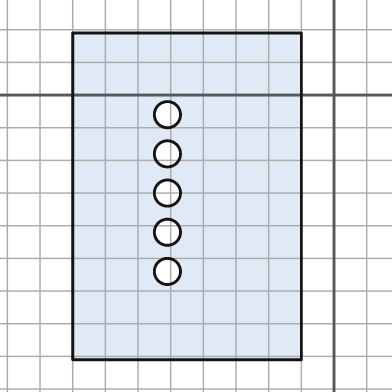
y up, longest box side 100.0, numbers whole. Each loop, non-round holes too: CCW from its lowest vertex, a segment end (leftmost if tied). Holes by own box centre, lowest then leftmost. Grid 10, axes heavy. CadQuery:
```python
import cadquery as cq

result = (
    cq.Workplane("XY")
    .moveTo(-80.0, -81.0)
    .lineTo(-10.0, -81.0)
    .lineTo(-10.0, 19.0)
    .lineTo(-80.0, 19.0)
    .close()
    .moveTo(-51.0, -54.0)
    .circle(4.0)
    .moveTo(-51.0, -42.0)
    .circle(4.0)
    .moveTo(-51.0, -30.0)
    .circle(4.0)
    .moveTo(-51.0, -18.0)
    .circle(4.0)
    .moveTo(-51.0, -6.0)
    .circle(4.0)
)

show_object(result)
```